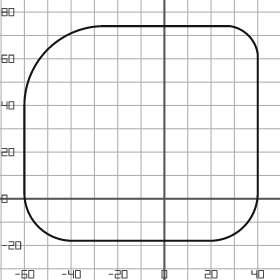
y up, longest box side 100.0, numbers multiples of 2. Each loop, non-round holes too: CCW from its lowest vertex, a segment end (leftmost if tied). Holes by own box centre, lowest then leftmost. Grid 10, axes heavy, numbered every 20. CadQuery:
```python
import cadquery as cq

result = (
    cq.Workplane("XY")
    .moveTo(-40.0, -18.0)
    .lineTo(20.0, -18.0)
    .threePointArc((34.0, -12.0), (40.0, 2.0))
    .lineTo(40.0, 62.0)
    .threePointArc((36.0, 70.0), (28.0, 74.0))
    .lineTo(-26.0, 74.0)
    .threePointArc((-50.0, 64.0), (-60.0, 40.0))
    .lineTo(-60.0, 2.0)
    .threePointArc((-54.0, -12.0), (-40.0, -18.0))
    .close()
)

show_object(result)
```